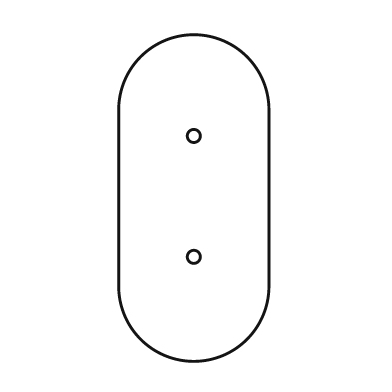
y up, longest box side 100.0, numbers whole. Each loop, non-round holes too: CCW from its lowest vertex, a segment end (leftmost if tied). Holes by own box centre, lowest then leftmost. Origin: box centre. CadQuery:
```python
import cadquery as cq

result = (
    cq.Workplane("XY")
    .moveTo(-23.0, -27.0)
    .threePointArc((0.0, -50.0), (23.0, -27.0))
    .lineTo(23.0, 27.0)
    .threePointArc((0.0, 50.0), (-23.0, 27.0))
    .close()
    .moveTo(0.0, -18.0)
    .circle(2.0)
    .moveTo(0.0, 19.0)
    .circle(2.0)
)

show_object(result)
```